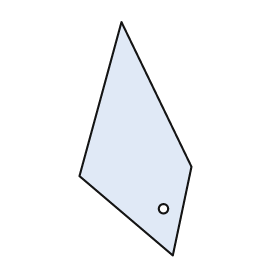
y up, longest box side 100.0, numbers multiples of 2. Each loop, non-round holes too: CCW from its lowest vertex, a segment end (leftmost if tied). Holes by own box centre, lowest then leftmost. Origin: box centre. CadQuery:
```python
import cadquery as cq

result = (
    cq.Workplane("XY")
    .moveTo(16.0, -50.0)
    .lineTo(24.0, -12.0)
    .lineTo(-6.0, 50.0)
    .lineTo(-24.0, -16.0)
    .close()
    .moveTo(12.0, -30.0)
    .circle(2.0)
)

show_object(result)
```